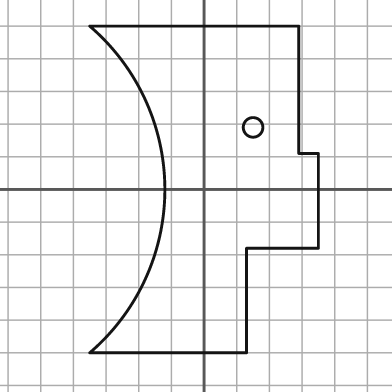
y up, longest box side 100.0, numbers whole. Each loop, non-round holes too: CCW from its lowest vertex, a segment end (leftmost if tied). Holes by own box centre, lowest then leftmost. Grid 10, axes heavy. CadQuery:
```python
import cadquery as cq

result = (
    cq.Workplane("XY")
    .moveTo(-35.0, -50.0)
    .lineTo(13.0, -50.0)
    .lineTo(13.0, -18.0)
    .lineTo(35.0, -18.0)
    .lineTo(35.0, 11.0)
    .lineTo(29.0, 11.0)
    .lineTo(29.0, 50.0)
    .lineTo(-35.0, 50.0)
    .threePointArc((-12.0, 0.0), (-35.0, -50.0))
    .close()
    .moveTo(15.0, 19.0)
    .circle(3.0)
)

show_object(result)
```